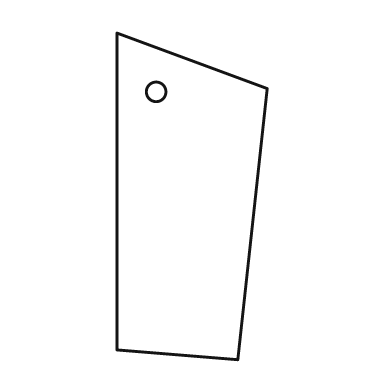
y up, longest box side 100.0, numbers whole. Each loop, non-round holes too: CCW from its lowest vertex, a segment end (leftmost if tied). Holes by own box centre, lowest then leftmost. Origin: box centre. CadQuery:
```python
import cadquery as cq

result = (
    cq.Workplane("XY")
    .moveTo(14.0, -50.0)
    .lineTo(23.0, 33.0)
    .lineTo(-23.0, 50.0)
    .lineTo(-23.0, -47.0)
    .close()
    .moveTo(-11.0, 32.0)
    .circle(3.0)
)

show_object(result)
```